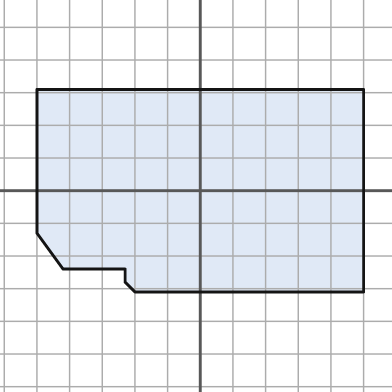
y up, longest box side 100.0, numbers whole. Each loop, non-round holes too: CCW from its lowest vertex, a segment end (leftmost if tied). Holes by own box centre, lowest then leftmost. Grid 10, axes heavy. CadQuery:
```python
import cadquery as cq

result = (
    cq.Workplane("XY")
    .moveTo(-20.0, -31.0)
    .lineTo(50.0, -31.0)
    .lineTo(50.0, 31.0)
    .lineTo(-50.0, 31.0)
    .lineTo(-50.0, -13.0)
    .lineTo(-42.0, -24.0)
    .lineTo(-23.0, -24.0)
    .lineTo(-23.0, -28.0)
    .close()
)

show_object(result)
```